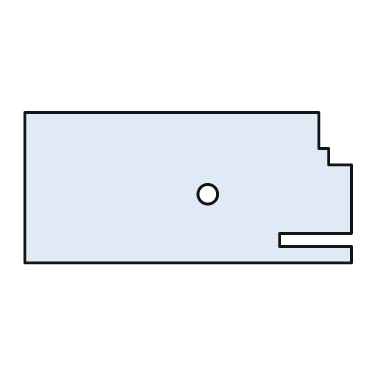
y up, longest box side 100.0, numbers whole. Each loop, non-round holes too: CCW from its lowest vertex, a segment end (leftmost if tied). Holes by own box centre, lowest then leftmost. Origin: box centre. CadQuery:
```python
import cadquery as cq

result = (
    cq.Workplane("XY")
    .moveTo(-50.0, -23.0)
    .lineTo(50.0, -23.0)
    .lineTo(50.0, -18.0)
    .lineTo(28.0, -18.0)
    .lineTo(28.0, -14.0)
    .lineTo(50.0, -14.0)
    .lineTo(50.0, 7.0)
    .lineTo(43.0, 7.0)
    .lineTo(43.0, 12.0)
    .lineTo(40.0, 12.0)
    .lineTo(40.0, 23.0)
    .lineTo(-50.0, 23.0)
    .close()
    .moveTo(6.0, -2.0)
    .circle(3.0)
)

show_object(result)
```